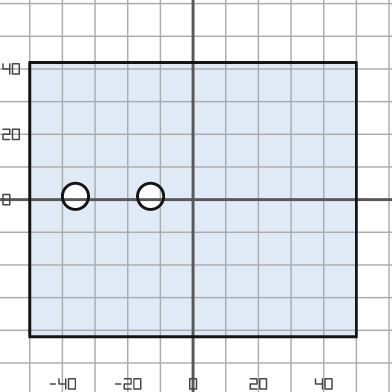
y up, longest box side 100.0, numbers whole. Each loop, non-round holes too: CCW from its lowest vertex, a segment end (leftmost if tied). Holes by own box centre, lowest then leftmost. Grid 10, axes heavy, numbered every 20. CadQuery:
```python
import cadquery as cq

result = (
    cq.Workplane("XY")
    .moveTo(-50.0, -42.0)
    .lineTo(50.0, -42.0)
    .lineTo(50.0, 42.0)
    .lineTo(-50.0, 42.0)
    .close()
    .moveTo(-36.0, 1.0)
    .circle(4.0)
    .moveTo(-13.0, 1.0)
    .circle(4.0)
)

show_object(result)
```